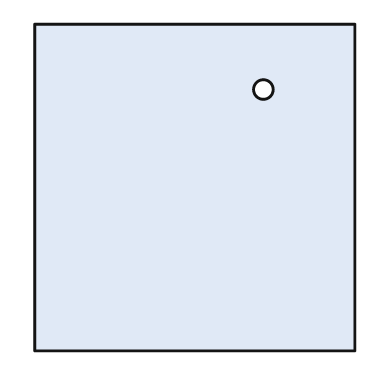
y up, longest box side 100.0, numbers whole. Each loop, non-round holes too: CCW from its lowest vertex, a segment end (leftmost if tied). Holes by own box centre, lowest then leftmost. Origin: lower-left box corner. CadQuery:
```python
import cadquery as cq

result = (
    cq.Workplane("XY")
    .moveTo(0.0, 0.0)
    .lineTo(98.0, 0.0)
    .lineTo(98.0, 100.0)
    .lineTo(0.0, 100.0)
    .close()
    .moveTo(70.0, 80.0)
    .circle(3.0)
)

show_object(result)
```